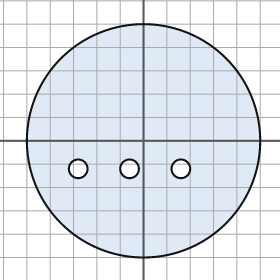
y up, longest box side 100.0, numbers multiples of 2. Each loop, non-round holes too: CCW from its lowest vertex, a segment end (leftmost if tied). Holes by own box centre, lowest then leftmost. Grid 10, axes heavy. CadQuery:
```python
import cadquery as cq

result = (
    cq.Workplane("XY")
    .moveTo(0.0, 0.0)
    .circle(50.0)
    .moveTo(-28.0, -12.0)
    .circle(4.0)
    .moveTo(-6.0, -12.0)
    .circle(4.0)
    .moveTo(16.0, -12.0)
    .circle(4.0)
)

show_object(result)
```